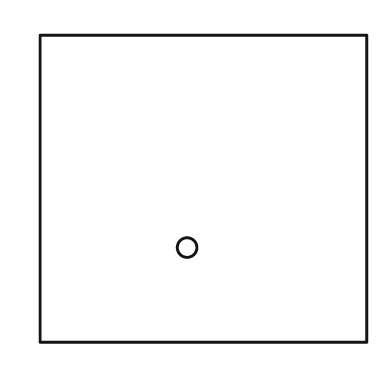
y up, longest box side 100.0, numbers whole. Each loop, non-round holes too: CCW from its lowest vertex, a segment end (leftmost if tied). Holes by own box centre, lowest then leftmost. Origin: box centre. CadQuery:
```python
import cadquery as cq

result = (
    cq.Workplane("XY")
    .moveTo(-50.0, -47.0)
    .lineTo(50.0, -47.0)
    .lineTo(50.0, 47.0)
    .lineTo(-50.0, 47.0)
    .close()
    .moveTo(-5.0, -18.0)
    .circle(3.0)
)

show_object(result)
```